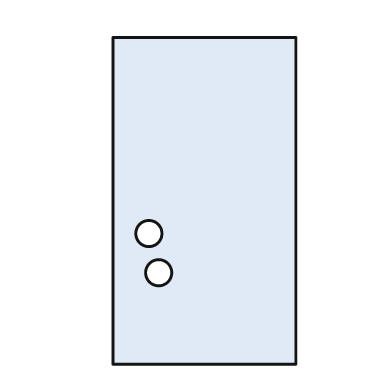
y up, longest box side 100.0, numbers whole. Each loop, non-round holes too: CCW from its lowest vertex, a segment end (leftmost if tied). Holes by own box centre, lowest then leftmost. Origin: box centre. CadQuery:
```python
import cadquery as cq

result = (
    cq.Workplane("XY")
    .moveTo(-28.0, -50.0)
    .lineTo(28.0, -50.0)
    .lineTo(28.0, 50.0)
    .lineTo(-28.0, 50.0)
    .close()
    .moveTo(-14.0, -22.0)
    .circle(4.0)
    .moveTo(-17.0, -10.0)
    .circle(4.0)
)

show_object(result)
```